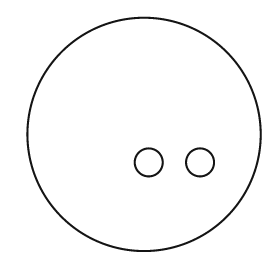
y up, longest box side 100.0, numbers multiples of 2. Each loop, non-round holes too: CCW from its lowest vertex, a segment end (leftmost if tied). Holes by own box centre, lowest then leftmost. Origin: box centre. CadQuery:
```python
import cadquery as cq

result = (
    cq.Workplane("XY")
    .moveTo(0.0, 0.0)
    .circle(50.0)
    .moveTo(2.0, -12.0)
    .circle(6.0)
    .moveTo(24.0, -12.0)
    .circle(6.0)
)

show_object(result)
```